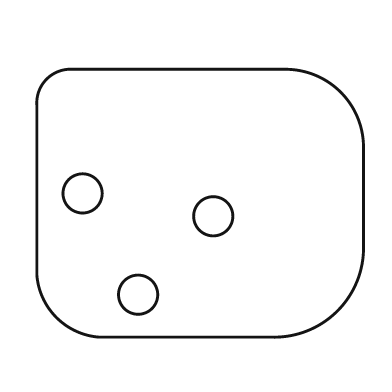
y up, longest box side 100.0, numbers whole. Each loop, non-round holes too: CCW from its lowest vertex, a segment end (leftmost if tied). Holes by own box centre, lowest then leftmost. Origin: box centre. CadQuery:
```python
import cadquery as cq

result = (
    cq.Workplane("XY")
    .moveTo(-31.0, -41.0)
    .lineTo(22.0, -41.0)
    .threePointArc((42.0, -33.0), (50.0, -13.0))
    .lineTo(50.0, 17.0)
    .threePointArc((43.0, 34.0), (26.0, 41.0))
    .lineTo(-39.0, 41.0)
    .threePointArc((-47.0, 38.0), (-50.0, 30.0))
    .lineTo(-50.0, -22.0)
    .threePointArc((-44.0, -35.0), (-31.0, -41.0))
    .close()
    .moveTo(-19.0, -28.0)
    .circle(6.0)
    .moveTo(4.0, -4.0)
    .circle(6.0)
    .moveTo(-36.0, 3.0)
    .circle(6.0)
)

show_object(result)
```